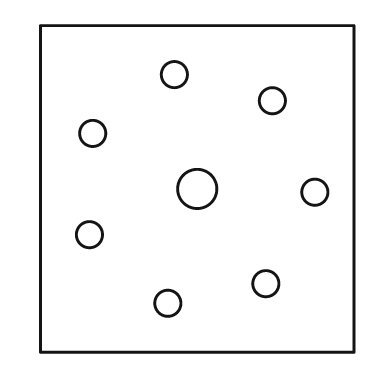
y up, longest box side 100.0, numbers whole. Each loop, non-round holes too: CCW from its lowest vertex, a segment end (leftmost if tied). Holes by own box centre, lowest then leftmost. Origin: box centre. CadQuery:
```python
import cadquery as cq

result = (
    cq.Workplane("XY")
    .moveTo(-48.0, -50.0)
    .lineTo(48.0, -50.0)
    .lineTo(48.0, 50.0)
    .lineTo(-48.0, 50.0)
    .close()
    .moveTo(-9.0, -35.0)
    .circle(4.0)
    .moveTo(21.0, -29.0)
    .circle(4.0)
    .moveTo(-33.0, -14.0)
    .circle(4.0)
    .moveTo(36.0, -1.0)
    .circle(4.0)
    .moveTo(0.0, 0.0)
    .circle(6.0)
    .moveTo(-32.0, 17.0)
    .circle(4.0)
    .moveTo(23.0, 27.0)
    .circle(4.0)
    .moveTo(-7.0, 35.0)
    .circle(4.0)
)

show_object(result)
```